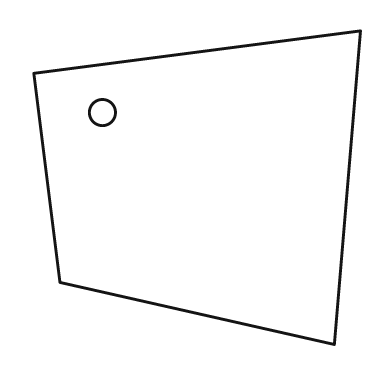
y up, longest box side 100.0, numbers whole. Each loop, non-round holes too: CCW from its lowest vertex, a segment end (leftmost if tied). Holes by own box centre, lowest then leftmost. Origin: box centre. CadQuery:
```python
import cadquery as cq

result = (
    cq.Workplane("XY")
    .moveTo(42.0, -48.0)
    .lineTo(50.0, 48.0)
    .lineTo(-50.0, 35.0)
    .lineTo(-42.0, -29.0)
    .close()
    .moveTo(-29.0, 23.0)
    .circle(4.0)
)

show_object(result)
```